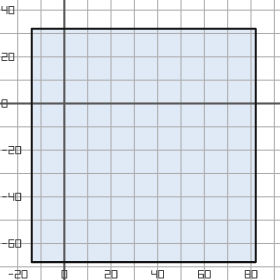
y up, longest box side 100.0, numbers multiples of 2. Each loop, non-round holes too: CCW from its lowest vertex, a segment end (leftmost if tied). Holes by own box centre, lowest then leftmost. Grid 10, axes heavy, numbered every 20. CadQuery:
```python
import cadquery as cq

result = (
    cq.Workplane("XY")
    .moveTo(-14.0, -68.0)
    .lineTo(82.0, -68.0)
    .lineTo(82.0, 32.0)
    .lineTo(-14.0, 32.0)
    .close()
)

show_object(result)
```